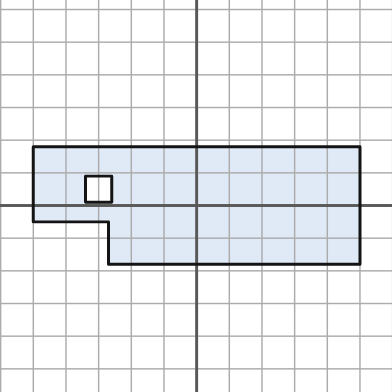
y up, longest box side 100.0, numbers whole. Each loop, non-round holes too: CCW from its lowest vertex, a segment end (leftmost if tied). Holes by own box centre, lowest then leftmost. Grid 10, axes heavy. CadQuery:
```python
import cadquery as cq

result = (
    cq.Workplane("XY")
    .moveTo(-27.0, -18.0)
    .lineTo(50.0, -18.0)
    .lineTo(50.0, 18.0)
    .lineTo(-50.0, 18.0)
    .lineTo(-50.0, -5.0)
    .lineTo(-27.0, -5.0)
    .close()
    .moveTo(-34.0, 1.0)
    .lineTo(-26.0, 1.0)
    .lineTo(-26.0, 9.0)
    .lineTo(-34.0, 9.0)
    .close()
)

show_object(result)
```